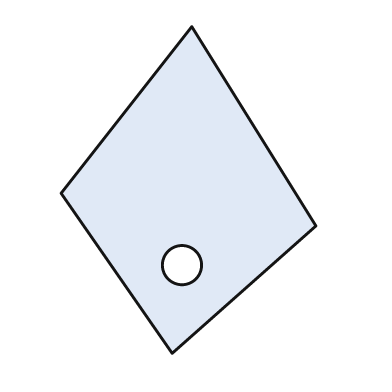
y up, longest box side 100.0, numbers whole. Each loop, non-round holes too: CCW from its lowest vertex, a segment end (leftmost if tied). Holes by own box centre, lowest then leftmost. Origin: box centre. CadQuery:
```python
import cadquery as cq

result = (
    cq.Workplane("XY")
    .moveTo(-5.0, -50.0)
    .lineTo(39.0, -11.0)
    .lineTo(1.0, 50.0)
    .lineTo(-39.0, -1.0)
    .close()
    .moveTo(-2.0, -23.0)
    .circle(6.0)
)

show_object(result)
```